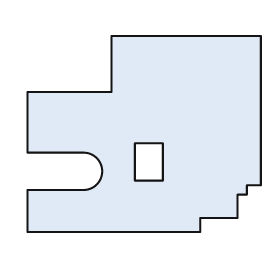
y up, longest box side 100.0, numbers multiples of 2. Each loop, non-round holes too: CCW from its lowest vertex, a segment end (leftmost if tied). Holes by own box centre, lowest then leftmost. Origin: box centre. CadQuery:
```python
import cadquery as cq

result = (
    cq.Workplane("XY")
    .moveTo(-50.0, -42.0)
    .lineTo(24.0, -42.0)
    .lineTo(24.0, -36.0)
    .lineTo(40.0, -36.0)
    .lineTo(40.0, -26.0)
    .lineTo(44.0, -26.0)
    .lineTo(44.0, -22.0)
    .lineTo(50.0, -22.0)
    .lineTo(50.0, 42.0)
    .lineTo(-14.0, 42.0)
    .lineTo(-14.0, 18.0)
    .lineTo(-50.0, 18.0)
    .lineTo(-50.0, -8.0)
    .lineTo(-26.0, -8.0)
    .threePointArc((-18.0, -16.0), (-26.0, -24.0))
    .lineTo(-50.0, -24.0)
    .close()
    .moveTo(-4.0, -20.0)
    .lineTo(8.0, -20.0)
    .lineTo(8.0, -4.0)
    .lineTo(-4.0, -4.0)
    .close()
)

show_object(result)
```